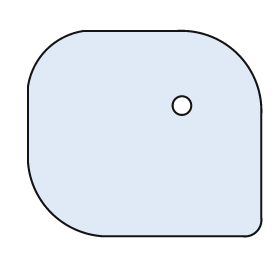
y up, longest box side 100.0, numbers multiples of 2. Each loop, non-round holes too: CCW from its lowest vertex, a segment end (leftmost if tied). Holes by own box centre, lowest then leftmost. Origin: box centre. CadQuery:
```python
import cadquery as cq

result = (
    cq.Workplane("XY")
    .moveTo(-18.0, -44.0)
    .lineTo(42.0, -44.0)
    .threePointArc((48.0, -42.0), (50.0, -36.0))
    .lineTo(50.0, 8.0)
    .threePointArc((40.0, 34.0), (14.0, 44.0))
    .lineTo(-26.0, 44.0)
    .threePointArc((-42.0, 36.0), (-50.0, 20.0))
    .lineTo(-50.0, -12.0)
    .threePointArc((-40.0, -34.0), (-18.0, -44.0))
    .close()
    .moveTo(16.0, 12.0)
    .circle(4.0)
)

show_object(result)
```